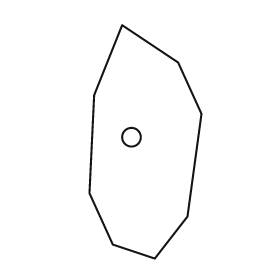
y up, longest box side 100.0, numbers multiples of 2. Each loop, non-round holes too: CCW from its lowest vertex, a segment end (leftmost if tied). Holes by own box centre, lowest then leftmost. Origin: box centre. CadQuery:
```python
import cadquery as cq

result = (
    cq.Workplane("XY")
    .moveTo(4.0, -50.0)
    .lineTo(18.0, -32.0)
    .lineTo(24.0, 12.0)
    .lineTo(14.0, 34.0)
    .lineTo(-10.0, 50.0)
    .lineTo(-22.0, 20.0)
    .lineTo(-24.0, -22.0)
    .lineTo(-14.0, -44.0)
    .close()
    .moveTo(-6.0, 2.0)
    .circle(4.0)
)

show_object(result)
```